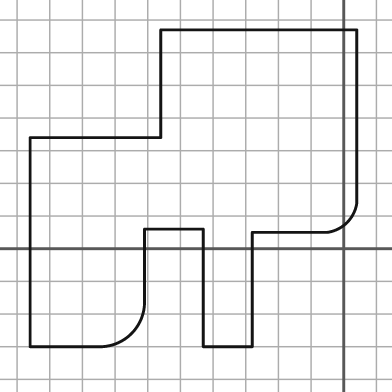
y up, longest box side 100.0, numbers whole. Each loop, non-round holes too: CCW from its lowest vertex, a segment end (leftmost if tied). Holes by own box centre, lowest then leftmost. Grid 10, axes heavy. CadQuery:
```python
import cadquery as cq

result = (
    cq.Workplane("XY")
    .moveTo(-96.0, -30.0)
    .lineTo(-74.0, -30.0)
    .threePointArc((-65.0, -26.0), (-61.0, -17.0))
    .lineTo(-61.0, 6.0)
    .lineTo(-43.0, 6.0)
    .lineTo(-43.0, -30.0)
    .lineTo(-28.0, -30.0)
    .lineTo(-28.0, 5.0)
    .lineTo(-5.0, 5.0)
    .threePointArc((1.0, 8.0), (4.0, 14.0))
    .lineTo(4.0, 67.0)
    .lineTo(-56.0, 67.0)
    .lineTo(-56.0, 34.0)
    .lineTo(-96.0, 34.0)
    .close()
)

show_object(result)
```